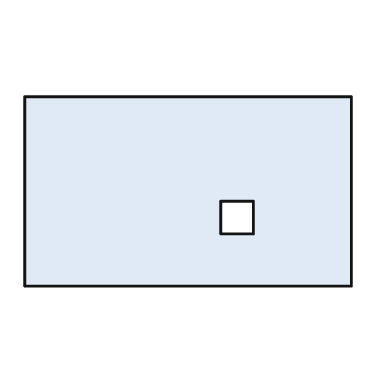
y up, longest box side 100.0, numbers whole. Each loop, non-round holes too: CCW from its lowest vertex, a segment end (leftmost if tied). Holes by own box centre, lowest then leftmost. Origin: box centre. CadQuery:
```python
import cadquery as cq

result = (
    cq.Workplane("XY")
    .moveTo(-50.0, -29.0)
    .lineTo(50.0, -29.0)
    .lineTo(50.0, 29.0)
    .lineTo(-50.0, 29.0)
    .close()
    .moveTo(10.0, -13.0)
    .lineTo(20.0, -13.0)
    .lineTo(20.0, -3.0)
    .lineTo(10.0, -3.0)
    .close()
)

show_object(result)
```